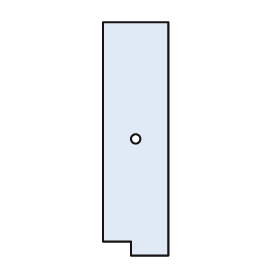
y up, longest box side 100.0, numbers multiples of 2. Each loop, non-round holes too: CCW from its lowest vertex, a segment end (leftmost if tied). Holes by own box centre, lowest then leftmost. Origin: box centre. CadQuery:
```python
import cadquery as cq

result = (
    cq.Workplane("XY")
    .moveTo(-2.0, -50.0)
    .lineTo(14.0, -50.0)
    .lineTo(14.0, 50.0)
    .lineTo(-14.0, 50.0)
    .lineTo(-14.0, -44.0)
    .lineTo(-2.0, -44.0)
    .close()
    .moveTo(0.0, 0.0)
    .circle(2.0)
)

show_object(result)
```